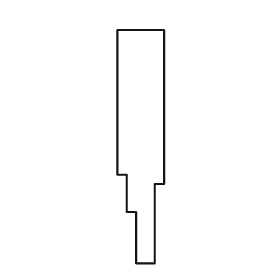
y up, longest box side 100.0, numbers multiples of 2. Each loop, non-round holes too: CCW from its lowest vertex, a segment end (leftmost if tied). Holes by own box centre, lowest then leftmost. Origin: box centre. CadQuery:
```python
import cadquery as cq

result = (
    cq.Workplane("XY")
    .moveTo(-2.0, -50.0)
    .lineTo(6.0, -50.0)
    .lineTo(6.0, -16.0)
    .lineTo(10.0, -16.0)
    .lineTo(10.0, 50.0)
    .lineTo(-10.0, 50.0)
    .lineTo(-10.0, -12.0)
    .lineTo(-6.0, -12.0)
    .lineTo(-6.0, -28.0)
    .lineTo(-2.0, -28.0)
    .close()
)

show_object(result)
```